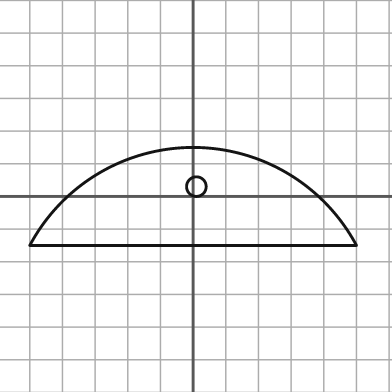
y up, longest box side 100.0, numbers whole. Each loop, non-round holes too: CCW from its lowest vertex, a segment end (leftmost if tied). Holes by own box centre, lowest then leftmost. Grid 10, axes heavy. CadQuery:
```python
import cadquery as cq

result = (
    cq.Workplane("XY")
    .moveTo(-50.0, -15.0)
    .lineTo(50.0, -15.0)
    .threePointArc((0.0, 15.0), (-50.0, -15.0))
    .close()
    .moveTo(1.0, 3.0)
    .circle(3.0)
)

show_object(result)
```